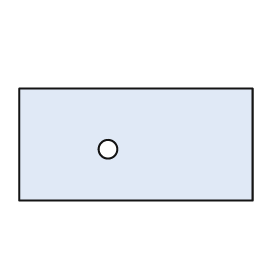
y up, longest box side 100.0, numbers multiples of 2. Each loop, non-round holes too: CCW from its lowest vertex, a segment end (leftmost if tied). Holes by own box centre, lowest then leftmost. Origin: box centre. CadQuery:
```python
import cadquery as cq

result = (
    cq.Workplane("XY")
    .moveTo(-50.0, -24.0)
    .lineTo(50.0, -24.0)
    .lineTo(50.0, 24.0)
    .lineTo(-50.0, 24.0)
    .close()
    .moveTo(-12.0, -2.0)
    .circle(4.0)
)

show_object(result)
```